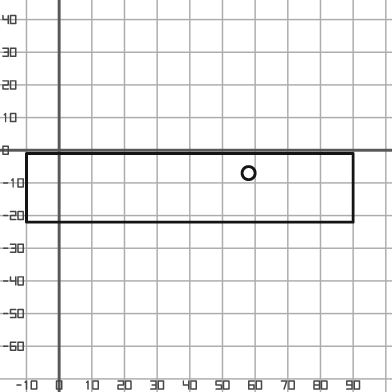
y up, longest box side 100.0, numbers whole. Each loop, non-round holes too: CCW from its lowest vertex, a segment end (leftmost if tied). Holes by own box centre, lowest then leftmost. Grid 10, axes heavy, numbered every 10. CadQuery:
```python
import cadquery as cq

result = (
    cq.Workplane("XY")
    .moveTo(-10.0, -22.0)
    .lineTo(90.0, -22.0)
    .lineTo(90.0, -1.0)
    .lineTo(-10.0, -1.0)
    .close()
    .moveTo(58.0, -7.0)
    .circle(2.0)
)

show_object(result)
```